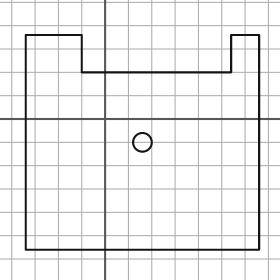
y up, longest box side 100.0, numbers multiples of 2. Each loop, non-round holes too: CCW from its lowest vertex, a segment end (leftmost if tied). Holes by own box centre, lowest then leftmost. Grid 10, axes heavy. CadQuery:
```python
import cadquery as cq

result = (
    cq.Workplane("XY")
    .moveTo(-34.0, -56.0)
    .lineTo(66.0, -56.0)
    .lineTo(66.0, 36.0)
    .lineTo(54.0, 36.0)
    .lineTo(54.0, 20.0)
    .lineTo(-10.0, 20.0)
    .lineTo(-10.0, 36.0)
    .lineTo(-34.0, 36.0)
    .close()
    .moveTo(16.0, -10.0)
    .circle(4.0)
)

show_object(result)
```